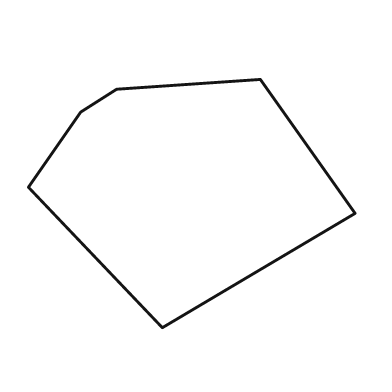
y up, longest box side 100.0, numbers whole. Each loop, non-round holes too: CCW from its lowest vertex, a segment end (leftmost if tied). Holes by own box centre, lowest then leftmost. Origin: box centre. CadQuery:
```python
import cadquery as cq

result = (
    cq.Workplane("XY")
    .moveTo(-9.0, -38.0)
    .lineTo(50.0, -3.0)
    .lineTo(21.0, 38.0)
    .lineTo(-23.0, 35.0)
    .lineTo(-34.0, 28.0)
    .lineTo(-50.0, 5.0)
    .close()
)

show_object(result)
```